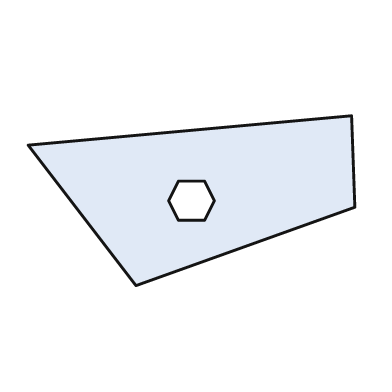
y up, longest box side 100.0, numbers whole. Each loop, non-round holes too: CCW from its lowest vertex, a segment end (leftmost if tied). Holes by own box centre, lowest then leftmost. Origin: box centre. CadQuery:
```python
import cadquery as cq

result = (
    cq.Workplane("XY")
    .moveTo(-17.0, -26.0)
    .lineTo(50.0, -2.0)
    .lineTo(49.0, 26.0)
    .lineTo(-50.0, 17.0)
    .close()
    .moveTo(-4.0, -6.0)
    .lineTo(4.0, -6.0)
    .lineTo(7.0, 0.0)
    .lineTo(4.0, 6.0)
    .lineTo(-4.0, 6.0)
    .lineTo(-7.0, 0.0)
    .close()
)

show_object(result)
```